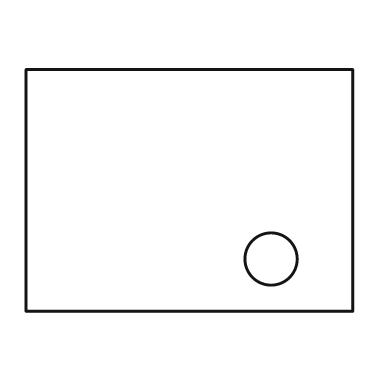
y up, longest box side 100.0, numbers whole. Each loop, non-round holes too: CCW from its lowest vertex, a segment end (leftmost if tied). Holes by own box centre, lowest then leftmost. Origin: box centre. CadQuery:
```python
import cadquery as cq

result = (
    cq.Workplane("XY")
    .moveTo(-50.0, -37.0)
    .lineTo(50.0, -37.0)
    .lineTo(50.0, 37.0)
    .lineTo(-50.0, 37.0)
    .close()
    .moveTo(25.0, -21.0)
    .circle(8.0)
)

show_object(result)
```